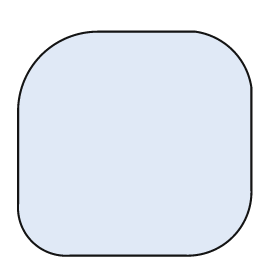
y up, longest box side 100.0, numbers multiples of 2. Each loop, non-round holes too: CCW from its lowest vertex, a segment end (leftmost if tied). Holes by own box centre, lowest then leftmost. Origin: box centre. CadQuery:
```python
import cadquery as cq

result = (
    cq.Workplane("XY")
    .moveTo(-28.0, -48.0)
    .lineTo(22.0, -48.0)
    .threePointArc((42.0, -40.0), (50.0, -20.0))
    .lineTo(50.0, 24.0)
    .threePointArc((42.0, 40.0), (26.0, 48.0))
    .lineTo(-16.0, 48.0)
    .threePointArc((-40.0, 38.0), (-50.0, 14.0))
    .lineTo(-50.0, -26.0)
    .threePointArc((-44.0, -42.0), (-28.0, -48.0))
    .close()
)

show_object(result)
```